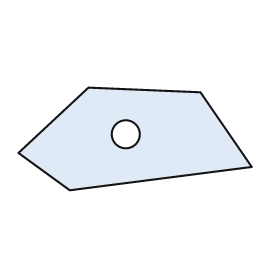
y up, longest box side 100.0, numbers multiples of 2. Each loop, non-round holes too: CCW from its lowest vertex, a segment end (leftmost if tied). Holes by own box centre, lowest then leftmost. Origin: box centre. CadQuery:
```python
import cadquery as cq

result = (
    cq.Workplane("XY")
    .moveTo(-28.0, -22.0)
    .lineTo(50.0, -12.0)
    .lineTo(28.0, 20.0)
    .lineTo(-20.0, 22.0)
    .lineTo(-50.0, -6.0)
    .close()
    .moveTo(-4.0, 2.0)
    .circle(6.0)
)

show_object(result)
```